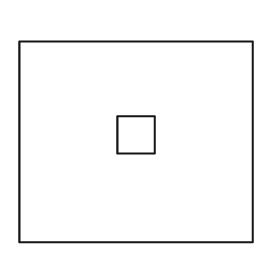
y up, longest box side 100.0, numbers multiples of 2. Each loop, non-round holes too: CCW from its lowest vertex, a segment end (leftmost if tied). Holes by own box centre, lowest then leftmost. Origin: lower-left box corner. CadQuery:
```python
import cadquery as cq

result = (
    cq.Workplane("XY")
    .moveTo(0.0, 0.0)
    .lineTo(100.0, 0.0)
    .lineTo(100.0, 86.0)
    .lineTo(0.0, 86.0)
    .close()
    .moveTo(42.0, 38.0)
    .lineTo(58.0, 38.0)
    .lineTo(58.0, 54.0)
    .lineTo(42.0, 54.0)
    .close()
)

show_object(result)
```